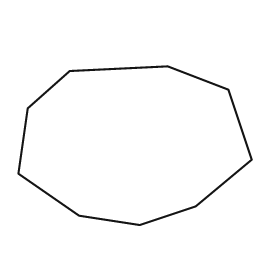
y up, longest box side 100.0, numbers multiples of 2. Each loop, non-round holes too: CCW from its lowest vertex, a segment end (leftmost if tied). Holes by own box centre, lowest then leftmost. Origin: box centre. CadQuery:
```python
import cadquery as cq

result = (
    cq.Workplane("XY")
    .moveTo(2.0, -34.0)
    .lineTo(26.0, -26.0)
    .lineTo(50.0, -6.0)
    .lineTo(40.0, 24.0)
    .lineTo(14.0, 34.0)
    .lineTo(-28.0, 32.0)
    .lineTo(-46.0, 16.0)
    .lineTo(-50.0, -12.0)
    .lineTo(-24.0, -30.0)
    .close()
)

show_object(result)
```